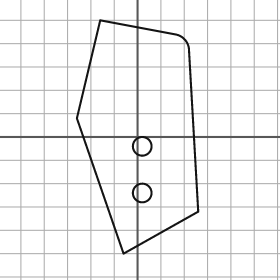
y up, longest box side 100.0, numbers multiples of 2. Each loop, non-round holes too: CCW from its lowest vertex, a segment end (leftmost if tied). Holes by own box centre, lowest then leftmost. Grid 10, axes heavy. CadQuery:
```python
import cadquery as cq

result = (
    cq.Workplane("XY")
    .moveTo(-6.0, -50.0)
    .lineTo(26.0, -32.0)
    .lineTo(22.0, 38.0)
    .threePointArc((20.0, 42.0), (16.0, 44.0))
    .lineTo(-16.0, 50.0)
    .lineTo(-26.0, 8.0)
    .close()
    .moveTo(2.0, -24.0)
    .circle(4.0)
    .moveTo(2.0, -4.0)
    .circle(4.0)
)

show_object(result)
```